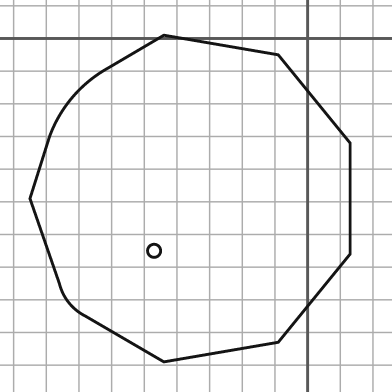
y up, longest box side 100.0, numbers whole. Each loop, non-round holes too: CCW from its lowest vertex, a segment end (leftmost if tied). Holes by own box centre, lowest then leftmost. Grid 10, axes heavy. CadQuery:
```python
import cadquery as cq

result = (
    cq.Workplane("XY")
    .moveTo(-44.0, -99.0)
    .lineTo(-9.0, -93.0)
    .lineTo(13.0, -66.0)
    .lineTo(13.0, -32.0)
    .lineTo(-9.0, -5.0)
    .lineTo(-44.0, 1.0)
    .lineTo(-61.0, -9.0)
    .threePointArc((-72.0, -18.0), (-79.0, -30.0))
    .lineTo(-85.0, -49.0)
    .lineTo(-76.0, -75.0)
    .threePointArc((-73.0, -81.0), (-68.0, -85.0))
    .close()
    .moveTo(-47.0, -65.0)
    .circle(2.0)
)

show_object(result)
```